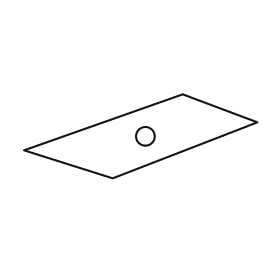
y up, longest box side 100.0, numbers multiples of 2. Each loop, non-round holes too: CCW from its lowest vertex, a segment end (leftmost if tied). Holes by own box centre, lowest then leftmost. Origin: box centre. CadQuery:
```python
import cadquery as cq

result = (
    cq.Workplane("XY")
    .moveTo(-12.0, -18.0)
    .lineTo(50.0, 6.0)
    .lineTo(18.0, 18.0)
    .lineTo(-50.0, -6.0)
    .close()
    .moveTo(2.0, 0.0)
    .circle(4.0)
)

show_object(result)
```